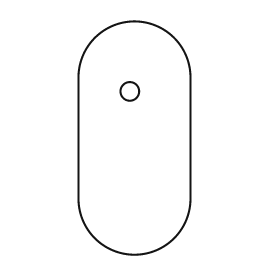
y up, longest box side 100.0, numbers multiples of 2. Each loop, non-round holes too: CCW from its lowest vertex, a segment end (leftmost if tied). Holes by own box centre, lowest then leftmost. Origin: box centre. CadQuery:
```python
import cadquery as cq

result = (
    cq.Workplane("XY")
    .moveTo(-24.0, -26.0)
    .threePointArc((0.0, -50.0), (24.0, -26.0))
    .lineTo(24.0, 26.0)
    .threePointArc((0.0, 50.0), (-24.0, 26.0))
    .close()
    .moveTo(-2.0, 20.0)
    .circle(4.0)
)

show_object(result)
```